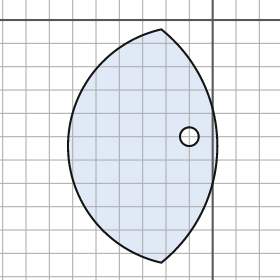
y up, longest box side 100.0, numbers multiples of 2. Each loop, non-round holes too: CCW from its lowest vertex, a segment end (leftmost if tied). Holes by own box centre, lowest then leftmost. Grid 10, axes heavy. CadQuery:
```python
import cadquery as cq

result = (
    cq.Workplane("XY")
    .moveTo(-22.0, -104.0)
    .threePointArc((2.0, -54.0), (-22.0, -4.0))
    .threePointArc((-62.0, -54.0), (-22.0, -104.0))
    .close()
    .moveTo(-10.0, -50.0)
    .circle(4.0)
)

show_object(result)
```